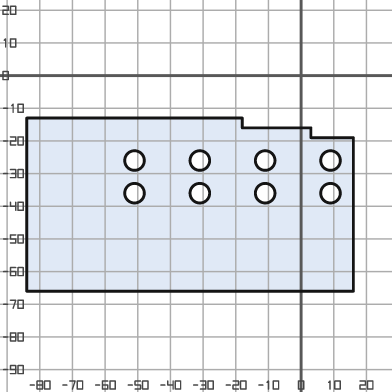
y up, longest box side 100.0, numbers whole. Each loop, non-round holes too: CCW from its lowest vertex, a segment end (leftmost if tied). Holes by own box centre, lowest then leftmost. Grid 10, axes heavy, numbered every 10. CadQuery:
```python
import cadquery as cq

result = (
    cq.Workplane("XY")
    .moveTo(-84.0, -66.0)
    .lineTo(16.0, -66.0)
    .lineTo(16.0, -19.0)
    .lineTo(3.0, -19.0)
    .lineTo(3.0, -16.0)
    .lineTo(-18.0, -16.0)
    .lineTo(-18.0, -13.0)
    .lineTo(-84.0, -13.0)
    .close()
    .moveTo(-51.0, -36.0)
    .circle(3.0)
    .moveTo(-31.0, -36.0)
    .circle(3.0)
    .moveTo(-11.0, -36.0)
    .circle(3.0)
    .moveTo(9.0, -36.0)
    .circle(3.0)
    .moveTo(-51.0, -26.0)
    .circle(3.0)
    .moveTo(-31.0, -26.0)
    .circle(3.0)
    .moveTo(-11.0, -26.0)
    .circle(3.0)
    .moveTo(9.0, -26.0)
    .circle(3.0)
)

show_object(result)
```